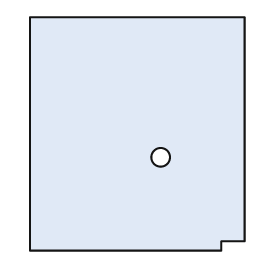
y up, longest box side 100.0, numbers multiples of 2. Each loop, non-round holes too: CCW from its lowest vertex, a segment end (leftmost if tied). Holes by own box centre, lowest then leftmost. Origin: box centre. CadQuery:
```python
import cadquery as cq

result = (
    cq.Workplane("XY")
    .moveTo(-46.0, -50.0)
    .lineTo(36.0, -50.0)
    .lineTo(36.0, -46.0)
    .lineTo(46.0, -46.0)
    .lineTo(46.0, 50.0)
    .lineTo(-46.0, 50.0)
    .close()
    .moveTo(10.0, -10.0)
    .circle(4.0)
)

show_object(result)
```